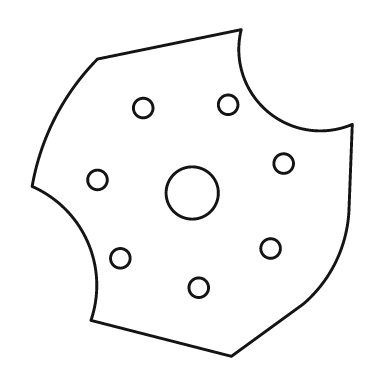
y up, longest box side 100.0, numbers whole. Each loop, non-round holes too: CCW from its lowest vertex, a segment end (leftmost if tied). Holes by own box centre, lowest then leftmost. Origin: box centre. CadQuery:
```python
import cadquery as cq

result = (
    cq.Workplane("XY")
    .moveTo(12.0, -50.0)
    .lineTo(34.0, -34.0)
    .threePointArc((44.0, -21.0), (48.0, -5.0))
    .lineTo(49.0, 21.0)
    .threePointArc((23.0, 25.0), (15.0, 50.0))
    .lineTo(-29.0, 41.0)
    .threePointArc((-42.0, 23.0), (-49.0, 2.0))
    .threePointArc((-32.0, -15.0), (-31.0, -39.0))
    .close()
    .moveTo(2.0, -29.0)
    .circle(3.0)
    .moveTo(-22.0, -20.0)
    .circle(3.0)
    .moveTo(24.0, -17.0)
    .circle(3.0)
    .moveTo(0.0, 0.0)
    .circle(8.0)
    .moveTo(-29.0, 4.0)
    .circle(3.0)
    .moveTo(28.0, 9.0)
    .circle(3.0)
    .moveTo(-15.0, 26.0)
    .circle(3.0)
    .moveTo(11.0, 27.0)
    .circle(3.0)
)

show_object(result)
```